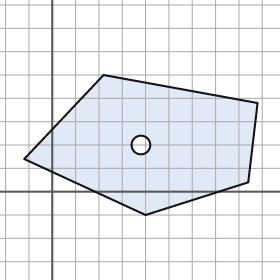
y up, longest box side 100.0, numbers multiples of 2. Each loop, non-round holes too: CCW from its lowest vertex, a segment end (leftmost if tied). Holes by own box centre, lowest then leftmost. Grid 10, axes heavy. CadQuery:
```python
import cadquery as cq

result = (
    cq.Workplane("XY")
    .moveTo(40.0, -10.0)
    .lineTo(84.0, 4.0)
    .lineTo(88.0, 38.0)
    .lineTo(22.0, 50.0)
    .lineTo(-12.0, 14.0)
    .close()
    .moveTo(38.0, 20.0)
    .circle(4.0)
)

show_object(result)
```